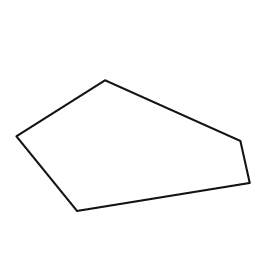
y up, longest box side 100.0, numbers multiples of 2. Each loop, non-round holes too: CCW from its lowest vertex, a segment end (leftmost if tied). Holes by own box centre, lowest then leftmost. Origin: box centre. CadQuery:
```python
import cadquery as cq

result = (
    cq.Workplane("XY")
    .moveTo(-24.0, -28.0)
    .lineTo(50.0, -16.0)
    .lineTo(46.0, 2.0)
    .lineTo(-12.0, 28.0)
    .lineTo(-50.0, 4.0)
    .close()
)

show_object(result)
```